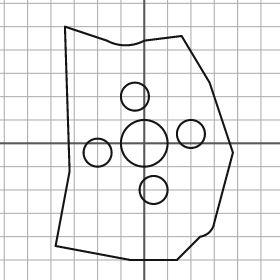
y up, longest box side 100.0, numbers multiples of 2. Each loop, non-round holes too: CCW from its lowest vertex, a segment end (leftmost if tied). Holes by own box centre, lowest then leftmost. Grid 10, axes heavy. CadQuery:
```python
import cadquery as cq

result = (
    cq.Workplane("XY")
    .moveTo(-6.0, -50.0)
    .lineTo(14.0, -50.0)
    .lineTo(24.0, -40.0)
    .threePointArc((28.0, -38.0), (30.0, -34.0))
    .lineTo(38.0, -4.0)
    .lineTo(28.0, 26.0)
    .lineTo(16.0, 46.0)
    .lineTo(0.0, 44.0)
    .threePointArc((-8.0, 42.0), (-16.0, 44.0))
    .lineTo(-34.0, 50.0)
    .lineTo(-32.0, -12.0)
    .lineTo(-38.0, -44.0)
    .close()
    .moveTo(4.0, -20.0)
    .circle(6.0)
    .moveTo(-20.0, -4.0)
    .circle(6.0)
    .moveTo(0.0, 0.0)
    .circle(10.0)
    .moveTo(20.0, 4.0)
    .circle(6.0)
    .moveTo(-4.0, 20.0)
    .circle(6.0)
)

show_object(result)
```